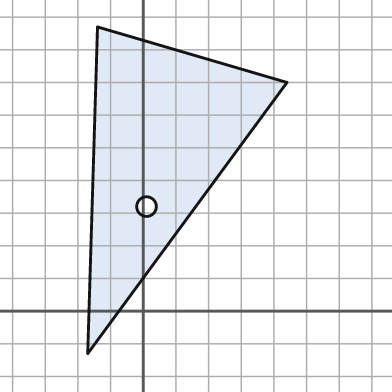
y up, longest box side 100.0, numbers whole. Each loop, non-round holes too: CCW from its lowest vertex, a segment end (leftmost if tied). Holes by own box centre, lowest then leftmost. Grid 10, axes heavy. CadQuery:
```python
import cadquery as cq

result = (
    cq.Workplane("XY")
    .moveTo(-17.0, -13.0)
    .lineTo(44.0, 70.0)
    .lineTo(-14.0, 87.0)
    .close()
    .moveTo(1.0, 32.0)
    .circle(3.0)
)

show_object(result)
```